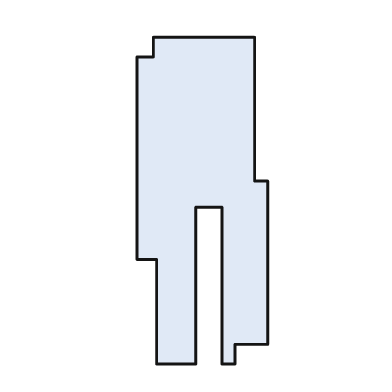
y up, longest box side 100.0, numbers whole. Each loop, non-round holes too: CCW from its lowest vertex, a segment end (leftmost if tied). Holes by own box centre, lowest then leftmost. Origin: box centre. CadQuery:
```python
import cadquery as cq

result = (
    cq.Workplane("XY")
    .moveTo(-14.0, -50.0)
    .lineTo(-2.0, -50.0)
    .lineTo(-2.0, -2.0)
    .lineTo(6.0, -2.0)
    .lineTo(6.0, -50.0)
    .lineTo(10.0, -50.0)
    .lineTo(10.0, -44.0)
    .lineTo(20.0, -44.0)
    .lineTo(20.0, 6.0)
    .lineTo(16.0, 6.0)
    .lineTo(16.0, 50.0)
    .lineTo(-15.0, 50.0)
    .lineTo(-15.0, 44.0)
    .lineTo(-20.0, 44.0)
    .lineTo(-20.0, -18.0)
    .lineTo(-14.0, -18.0)
    .close()
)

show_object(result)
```